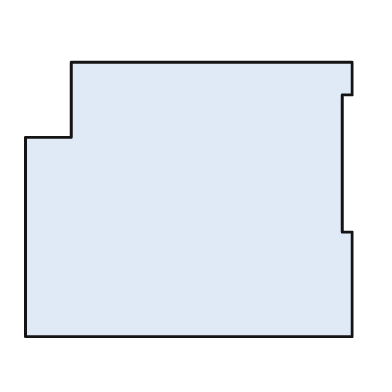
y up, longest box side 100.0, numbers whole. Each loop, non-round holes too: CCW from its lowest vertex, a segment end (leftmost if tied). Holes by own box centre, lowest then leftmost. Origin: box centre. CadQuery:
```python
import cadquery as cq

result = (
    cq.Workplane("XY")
    .moveTo(-50.0, -42.0)
    .lineTo(50.0, -42.0)
    .lineTo(50.0, -10.0)
    .lineTo(47.0, -10.0)
    .lineTo(47.0, 32.0)
    .lineTo(50.0, 32.0)
    .lineTo(50.0, 42.0)
    .lineTo(-36.0, 42.0)
    .lineTo(-36.0, 19.0)
    .lineTo(-50.0, 19.0)
    .close()
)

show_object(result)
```